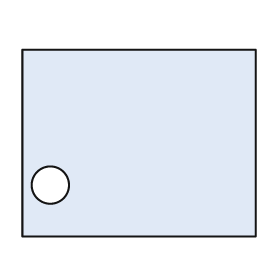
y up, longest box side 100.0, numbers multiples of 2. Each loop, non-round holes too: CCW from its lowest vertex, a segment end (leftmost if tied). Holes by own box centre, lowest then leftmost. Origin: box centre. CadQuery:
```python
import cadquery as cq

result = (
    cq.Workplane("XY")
    .moveTo(-50.0, -40.0)
    .lineTo(50.0, -40.0)
    .lineTo(50.0, 40.0)
    .lineTo(-50.0, 40.0)
    .close()
    .moveTo(-38.0, -18.0)
    .circle(8.0)
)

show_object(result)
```